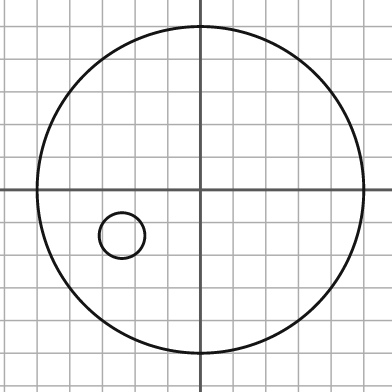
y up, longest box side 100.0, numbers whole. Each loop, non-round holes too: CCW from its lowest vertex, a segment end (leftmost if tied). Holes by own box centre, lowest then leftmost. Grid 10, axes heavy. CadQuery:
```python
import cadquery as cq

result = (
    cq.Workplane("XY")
    .moveTo(0.0, 0.0)
    .circle(50.0)
    .moveTo(-24.0, -14.0)
    .circle(7.0)
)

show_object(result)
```